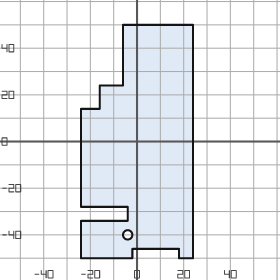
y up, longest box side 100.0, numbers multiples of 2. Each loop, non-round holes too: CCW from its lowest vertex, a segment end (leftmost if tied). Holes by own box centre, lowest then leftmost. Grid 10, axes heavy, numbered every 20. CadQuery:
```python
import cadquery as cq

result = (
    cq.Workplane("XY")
    .moveTo(-24.0, -50.0)
    .lineTo(-2.0, -50.0)
    .lineTo(-2.0, -46.0)
    .lineTo(18.0, -46.0)
    .lineTo(18.0, -50.0)
    .lineTo(24.0, -50.0)
    .lineTo(24.0, 50.0)
    .lineTo(-6.0, 50.0)
    .lineTo(-6.0, 24.0)
    .lineTo(-16.0, 24.0)
    .lineTo(-16.0, 14.0)
    .lineTo(-24.0, 14.0)
    .lineTo(-24.0, -28.0)
    .lineTo(-4.0, -28.0)
    .lineTo(-4.0, -34.0)
    .lineTo(-24.0, -34.0)
    .close()
    .moveTo(-4.0, -40.0)
    .circle(2.0)
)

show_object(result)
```